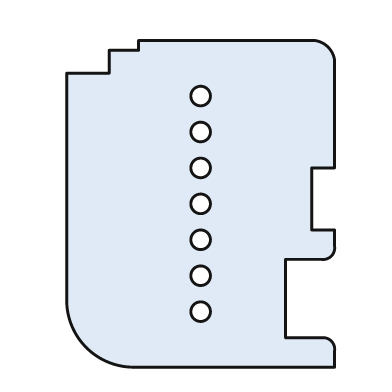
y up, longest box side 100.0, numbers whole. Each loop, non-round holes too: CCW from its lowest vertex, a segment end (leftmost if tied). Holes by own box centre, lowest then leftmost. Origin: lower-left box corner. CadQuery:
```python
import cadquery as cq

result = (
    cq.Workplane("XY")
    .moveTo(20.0, 0.0)
    .lineTo(82.0, 0.0)
    .lineTo(82.0, 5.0)
    .threePointArc((81.0, 8.0), (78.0, 9.0))
    .lineTo(67.0, 9.0)
    .lineTo(67.0, 33.0)
    .lineTo(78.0, 33.0)
    .threePointArc((81.0, 34.0), (82.0, 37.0))
    .lineTo(82.0, 42.0)
    .lineTo(75.0, 42.0)
    .lineTo(75.0, 61.0)
    .lineTo(82.0, 61.0)
    .lineTo(82.0, 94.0)
    .threePointArc((80.0, 98.0), (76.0, 100.0))
    .lineTo(22.0, 100.0)
    .lineTo(22.0, 97.0)
    .lineTo(13.0, 97.0)
    .lineTo(13.0, 90.0)
    .lineTo(0.0, 90.0)
    .lineTo(0.0, 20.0)
    .threePointArc((6.0, 6.0), (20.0, 0.0))
    .close()
    .moveTo(41.0, 17.0)
    .circle(3.0)
    .moveTo(41.0, 28.0)
    .circle(3.0)
    .moveTo(41.0, 39.0)
    .circle(3.0)
    .moveTo(41.0, 50.0)
    .circle(3.0)
    .moveTo(41.0, 61.0)
    .circle(3.0)
    .moveTo(41.0, 72.0)
    .circle(3.0)
    .moveTo(41.0, 83.0)
    .circle(3.0)
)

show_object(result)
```